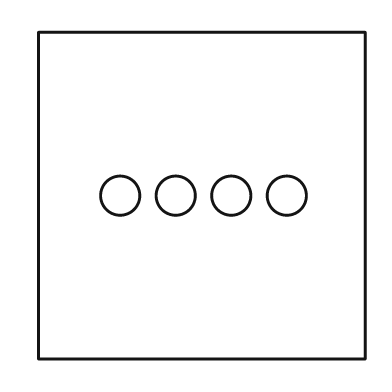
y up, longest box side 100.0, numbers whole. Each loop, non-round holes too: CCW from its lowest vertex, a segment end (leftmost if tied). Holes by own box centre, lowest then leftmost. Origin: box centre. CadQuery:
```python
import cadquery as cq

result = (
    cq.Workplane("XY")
    .moveTo(-50.0, -50.0)
    .lineTo(50.0, -50.0)
    .lineTo(50.0, 50.0)
    .lineTo(-50.0, 50.0)
    .close()
    .moveTo(-25.0, 0.0)
    .circle(6.0)
    .moveTo(-8.0, 0.0)
    .circle(6.0)
    .moveTo(9.0, 0.0)
    .circle(6.0)
    .moveTo(26.0, 0.0)
    .circle(6.0)
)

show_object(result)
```